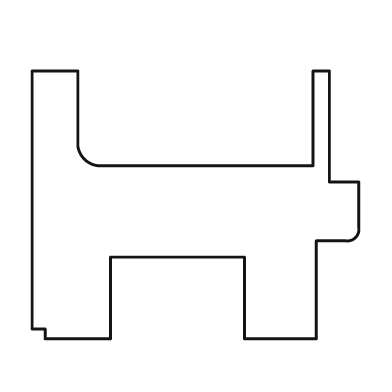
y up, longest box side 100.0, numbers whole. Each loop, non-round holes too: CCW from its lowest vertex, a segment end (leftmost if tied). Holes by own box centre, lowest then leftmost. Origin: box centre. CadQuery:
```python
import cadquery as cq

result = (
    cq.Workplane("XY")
    .moveTo(-46.0, -41.0)
    .lineTo(-26.0, -41.0)
    .lineTo(-26.0, -16.0)
    .lineTo(15.0, -16.0)
    .lineTo(15.0, -41.0)
    .lineTo(37.0, -41.0)
    .lineTo(37.0, -11.0)
    .lineTo(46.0, -11.0)
    .threePointArc((49.0, -10.0), (50.0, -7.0))
    .lineTo(50.0, 7.0)
    .lineTo(41.0, 7.0)
    .lineTo(41.0, 41.0)
    .lineTo(36.0, 41.0)
    .lineTo(36.0, 12.0)
    .lineTo(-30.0, 12.0)
    .threePointArc((-34.0, 14.0), (-36.0, 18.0))
    .lineTo(-36.0, 41.0)
    .lineTo(-50.0, 41.0)
    .lineTo(-50.0, -38.0)
    .lineTo(-46.0, -38.0)
    .close()
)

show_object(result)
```